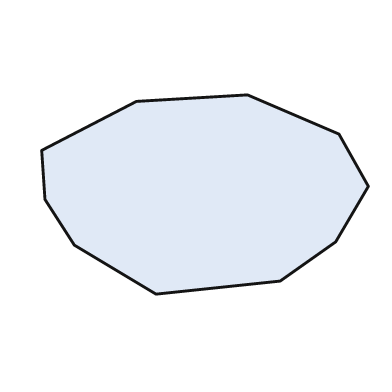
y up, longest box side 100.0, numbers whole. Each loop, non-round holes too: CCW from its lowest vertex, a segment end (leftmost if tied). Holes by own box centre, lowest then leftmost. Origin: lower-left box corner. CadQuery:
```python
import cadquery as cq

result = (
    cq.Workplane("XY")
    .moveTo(35.0, 0.0)
    .lineTo(73.0, 4.0)
    .lineTo(90.0, 16.0)
    .lineTo(100.0, 33.0)
    .lineTo(91.0, 49.0)
    .lineTo(63.0, 61.0)
    .lineTo(29.0, 59.0)
    .lineTo(0.0, 44.0)
    .lineTo(1.0, 29.0)
    .lineTo(10.0, 15.0)
    .close()
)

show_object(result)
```